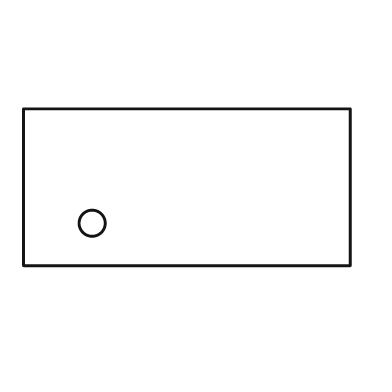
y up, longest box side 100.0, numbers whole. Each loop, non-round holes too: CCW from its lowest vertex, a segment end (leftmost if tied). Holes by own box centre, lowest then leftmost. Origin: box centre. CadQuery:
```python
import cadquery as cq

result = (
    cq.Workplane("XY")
    .moveTo(-50.0, -24.0)
    .lineTo(50.0, -24.0)
    .lineTo(50.0, 24.0)
    .lineTo(-50.0, 24.0)
    .close()
    .moveTo(-29.0, -11.0)
    .circle(4.0)
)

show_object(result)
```